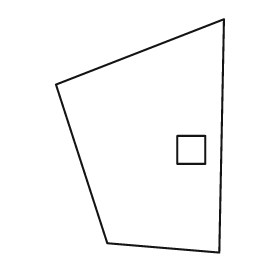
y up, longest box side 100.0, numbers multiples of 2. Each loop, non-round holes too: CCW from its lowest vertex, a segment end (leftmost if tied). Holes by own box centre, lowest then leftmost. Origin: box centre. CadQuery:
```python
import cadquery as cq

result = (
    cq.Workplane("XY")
    .moveTo(34.0, -50.0)
    .lineTo(36.0, 50.0)
    .lineTo(-36.0, 22.0)
    .lineTo(-14.0, -46.0)
    .close()
    .moveTo(16.0, -12.0)
    .lineTo(28.0, -12.0)
    .lineTo(28.0, 0.0)
    .lineTo(16.0, 0.0)
    .close()
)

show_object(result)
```